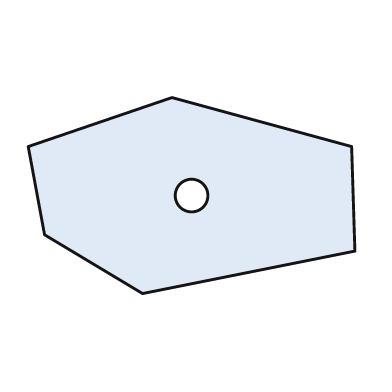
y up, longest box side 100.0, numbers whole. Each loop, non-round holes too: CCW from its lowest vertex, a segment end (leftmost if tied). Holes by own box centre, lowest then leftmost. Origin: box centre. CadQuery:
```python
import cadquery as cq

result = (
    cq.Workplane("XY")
    .moveTo(-15.0, -30.0)
    .lineTo(50.0, -17.0)
    .lineTo(49.0, 15.0)
    .lineTo(-6.0, 30.0)
    .lineTo(-50.0, 15.0)
    .lineTo(-45.0, -12.0)
    .close()
    .moveTo(0.0, 0.0)
    .circle(5.0)
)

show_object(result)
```